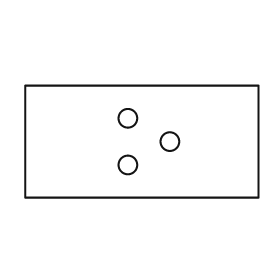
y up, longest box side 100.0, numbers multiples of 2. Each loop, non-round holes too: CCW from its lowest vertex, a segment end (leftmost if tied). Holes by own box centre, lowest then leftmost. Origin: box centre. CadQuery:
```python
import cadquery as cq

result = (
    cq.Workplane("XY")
    .moveTo(-50.0, -24.0)
    .lineTo(50.0, -24.0)
    .lineTo(50.0, 24.0)
    .lineTo(-50.0, 24.0)
    .close()
    .moveTo(-6.0, -10.0)
    .circle(4.0)
    .moveTo(12.0, 0.0)
    .circle(4.0)
    .moveTo(-6.0, 10.0)
    .circle(4.0)
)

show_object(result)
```